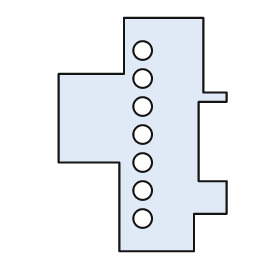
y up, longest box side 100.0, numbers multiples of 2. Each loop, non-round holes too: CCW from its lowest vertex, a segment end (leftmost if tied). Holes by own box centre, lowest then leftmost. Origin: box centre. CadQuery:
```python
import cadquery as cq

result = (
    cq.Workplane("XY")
    .moveTo(-10.0, -50.0)
    .lineTo(22.0, -50.0)
    .lineTo(22.0, -34.0)
    .lineTo(36.0, -34.0)
    .lineTo(36.0, -20.0)
    .lineTo(24.0, -20.0)
    .lineTo(24.0, 14.0)
    .lineTo(36.0, 14.0)
    .lineTo(36.0, 18.0)
    .lineTo(26.0, 18.0)
    .lineTo(26.0, 50.0)
    .lineTo(-8.0, 50.0)
    .lineTo(-8.0, 26.0)
    .lineTo(-36.0, 26.0)
    .lineTo(-36.0, -12.0)
    .lineTo(-10.0, -12.0)
    .close()
    .moveTo(0.0, -36.0)
    .circle(4.0)
    .moveTo(0.0, -24.0)
    .circle(4.0)
    .moveTo(0.0, -12.0)
    .circle(4.0)
    .moveTo(0.0, 0.0)
    .circle(4.0)
    .moveTo(0.0, 12.0)
    .circle(4.0)
    .moveTo(0.0, 24.0)
    .circle(4.0)
    .moveTo(0.0, 36.0)
    .circle(4.0)
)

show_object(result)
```